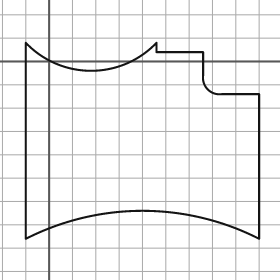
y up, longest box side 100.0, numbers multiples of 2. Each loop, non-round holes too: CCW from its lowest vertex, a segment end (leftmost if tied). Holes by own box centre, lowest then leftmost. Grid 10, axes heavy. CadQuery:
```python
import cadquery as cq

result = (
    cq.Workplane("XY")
    .moveTo(-10.0, -76.0)
    .threePointArc((40.0, -64.0), (90.0, -76.0))
    .lineTo(90.0, -14.0)
    .lineTo(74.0, -14.0)
    .threePointArc((68.0, -12.0), (66.0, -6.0))
    .lineTo(66.0, 4.0)
    .lineTo(46.0, 4.0)
    .lineTo(46.0, 8.0)
    .threePointArc((18.0, -4.0), (-10.0, 8.0))
    .close()
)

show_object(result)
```